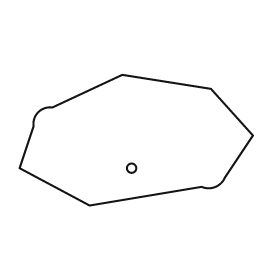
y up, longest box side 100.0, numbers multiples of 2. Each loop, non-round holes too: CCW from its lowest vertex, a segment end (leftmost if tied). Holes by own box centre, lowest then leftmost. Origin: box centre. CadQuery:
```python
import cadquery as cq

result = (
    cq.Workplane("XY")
    .moveTo(-20.0, -28.0)
    .lineTo(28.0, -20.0)
    .threePointArc((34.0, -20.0), (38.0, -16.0))
    .lineTo(50.0, 2.0)
    .lineTo(32.0, 22.0)
    .lineTo(-6.0, 28.0)
    .lineTo(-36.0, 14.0)
    .threePointArc((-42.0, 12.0), (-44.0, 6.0))
    .lineTo(-50.0, -12.0)
    .close()
    .moveTo(-2.0, -12.0)
    .circle(2.0)
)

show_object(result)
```